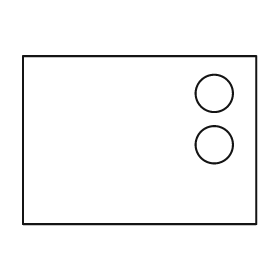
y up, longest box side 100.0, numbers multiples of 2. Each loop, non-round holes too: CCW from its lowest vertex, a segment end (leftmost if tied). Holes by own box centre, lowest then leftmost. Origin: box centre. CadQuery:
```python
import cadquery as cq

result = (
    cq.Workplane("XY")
    .moveTo(-50.0, -36.0)
    .lineTo(50.0, -36.0)
    .lineTo(50.0, 36.0)
    .lineTo(-50.0, 36.0)
    .close()
    .moveTo(32.0, -2.0)
    .circle(8.0)
    .moveTo(32.0, 20.0)
    .circle(8.0)
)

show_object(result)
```